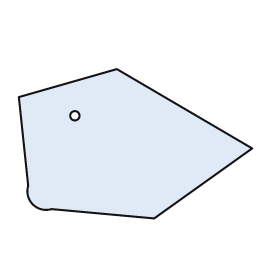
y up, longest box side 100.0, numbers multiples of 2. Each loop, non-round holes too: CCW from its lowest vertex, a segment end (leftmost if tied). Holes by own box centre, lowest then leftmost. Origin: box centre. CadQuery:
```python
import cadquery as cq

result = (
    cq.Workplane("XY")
    .moveTo(8.0, -32.0)
    .lineTo(50.0, -2.0)
    .lineTo(-8.0, 32.0)
    .lineTo(-50.0, 20.0)
    .lineTo(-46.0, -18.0)
    .threePointArc((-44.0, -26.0), (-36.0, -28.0))
    .close()
    .moveTo(-26.0, 12.0)
    .circle(2.0)
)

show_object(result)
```